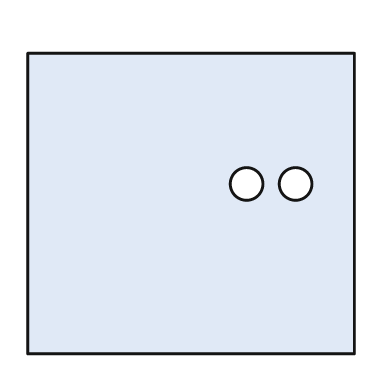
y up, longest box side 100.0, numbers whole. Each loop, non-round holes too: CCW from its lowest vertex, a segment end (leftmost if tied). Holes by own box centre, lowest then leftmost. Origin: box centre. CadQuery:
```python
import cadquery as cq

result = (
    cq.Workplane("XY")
    .moveTo(-50.0, -46.0)
    .lineTo(50.0, -46.0)
    .lineTo(50.0, 46.0)
    .lineTo(-50.0, 46.0)
    .close()
    .moveTo(17.0, 6.0)
    .circle(5.0)
    .moveTo(32.0, 6.0)
    .circle(5.0)
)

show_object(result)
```